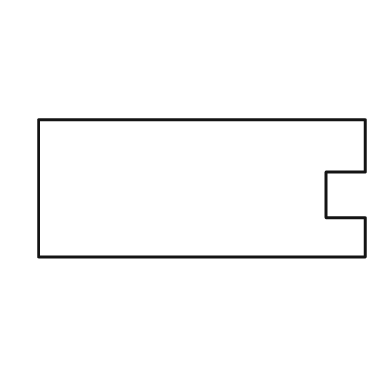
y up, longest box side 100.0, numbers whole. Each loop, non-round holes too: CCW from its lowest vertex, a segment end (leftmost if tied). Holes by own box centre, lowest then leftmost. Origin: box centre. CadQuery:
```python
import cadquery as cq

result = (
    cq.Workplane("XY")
    .moveTo(-50.0, -21.0)
    .lineTo(50.0, -21.0)
    .lineTo(50.0, -9.0)
    .lineTo(38.0, -9.0)
    .lineTo(38.0, 5.0)
    .lineTo(50.0, 5.0)
    .lineTo(50.0, 21.0)
    .lineTo(-50.0, 21.0)
    .close()
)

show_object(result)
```